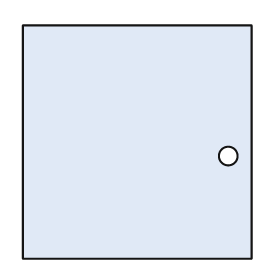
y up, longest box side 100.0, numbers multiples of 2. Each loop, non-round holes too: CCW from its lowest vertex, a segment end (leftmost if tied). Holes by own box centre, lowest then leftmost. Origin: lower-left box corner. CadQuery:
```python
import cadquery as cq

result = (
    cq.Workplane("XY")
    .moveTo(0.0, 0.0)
    .lineTo(98.0, 0.0)
    .lineTo(98.0, 100.0)
    .lineTo(0.0, 100.0)
    .close()
    .moveTo(88.0, 44.0)
    .circle(4.0)
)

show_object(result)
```